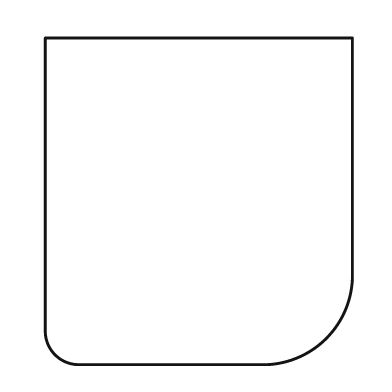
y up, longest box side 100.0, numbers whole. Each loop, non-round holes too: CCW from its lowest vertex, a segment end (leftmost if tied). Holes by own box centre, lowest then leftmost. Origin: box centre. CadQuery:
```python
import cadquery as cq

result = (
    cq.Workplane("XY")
    .moveTo(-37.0, -50.0)
    .lineTo(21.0, -50.0)
    .threePointArc((39.0, -42.0), (47.0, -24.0))
    .lineTo(47.0, 50.0)
    .lineTo(-47.0, 50.0)
    .lineTo(-47.0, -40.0)
    .threePointArc((-44.0, -47.0), (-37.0, -50.0))
    .close()
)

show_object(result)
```